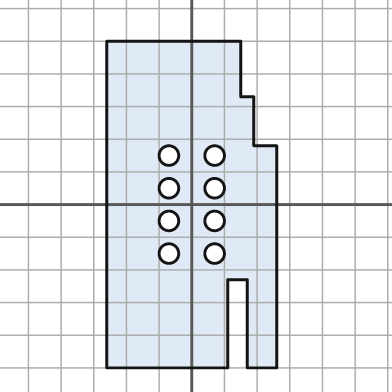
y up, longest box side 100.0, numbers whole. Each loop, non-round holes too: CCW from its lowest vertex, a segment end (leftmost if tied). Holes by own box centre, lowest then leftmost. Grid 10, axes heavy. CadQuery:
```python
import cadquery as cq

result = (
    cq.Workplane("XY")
    .moveTo(-26.0, -50.0)
    .lineTo(11.0, -50.0)
    .lineTo(11.0, -23.0)
    .lineTo(17.0, -23.0)
    .lineTo(17.0, -50.0)
    .lineTo(26.0, -50.0)
    .lineTo(26.0, 18.0)
    .lineTo(19.0, 18.0)
    .lineTo(19.0, 33.0)
    .lineTo(15.0, 33.0)
    .lineTo(15.0, 50.0)
    .lineTo(-26.0, 50.0)
    .close()
    .moveTo(-7.0, -15.0)
    .circle(3.0)
    .moveTo(7.0, -15.0)
    .circle(3.0)
    .moveTo(-7.0, -5.0)
    .circle(3.0)
    .moveTo(7.0, -5.0)
    .circle(3.0)
    .moveTo(-7.0, 5.0)
    .circle(3.0)
    .moveTo(7.0, 5.0)
    .circle(3.0)
    .moveTo(-7.0, 15.0)
    .circle(3.0)
    .moveTo(7.0, 15.0)
    .circle(3.0)
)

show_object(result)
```